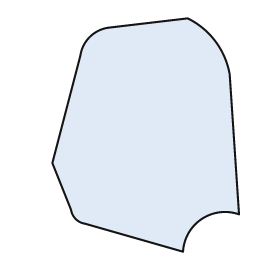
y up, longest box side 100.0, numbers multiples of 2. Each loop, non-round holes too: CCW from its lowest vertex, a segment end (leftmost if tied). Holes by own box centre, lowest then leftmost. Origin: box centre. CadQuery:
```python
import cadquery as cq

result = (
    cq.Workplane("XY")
    .moveTo(16.0, -50.0)
    .threePointArc((24.0, -36.0), (40.0, -34.0))
    .lineTo(36.0, 26.0)
    .threePointArc((30.0, 40.0), (18.0, 50.0))
    .lineTo(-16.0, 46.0)
    .threePointArc((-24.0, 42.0), (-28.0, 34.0))
    .lineTo(-40.0, -12.0)
    .lineTo(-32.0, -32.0)
    .threePointArc((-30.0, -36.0), (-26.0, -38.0))
    .close()
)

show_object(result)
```